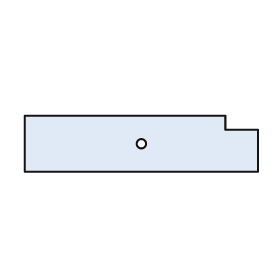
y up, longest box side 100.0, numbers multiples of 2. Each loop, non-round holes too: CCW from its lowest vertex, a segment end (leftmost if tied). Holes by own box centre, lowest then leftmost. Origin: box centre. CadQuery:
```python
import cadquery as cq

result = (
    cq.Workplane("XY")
    .moveTo(-50.0, -12.0)
    .lineTo(50.0, -12.0)
    .lineTo(50.0, 6.0)
    .lineTo(36.0, 6.0)
    .lineTo(36.0, 12.0)
    .lineTo(-50.0, 12.0)
    .close()
    .moveTo(0.0, 0.0)
    .circle(2.0)
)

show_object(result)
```